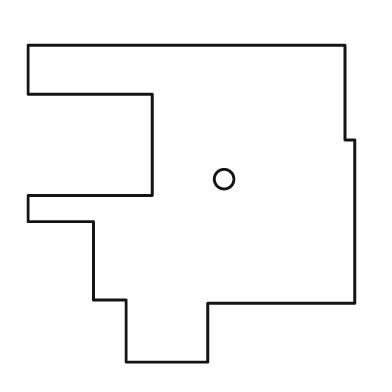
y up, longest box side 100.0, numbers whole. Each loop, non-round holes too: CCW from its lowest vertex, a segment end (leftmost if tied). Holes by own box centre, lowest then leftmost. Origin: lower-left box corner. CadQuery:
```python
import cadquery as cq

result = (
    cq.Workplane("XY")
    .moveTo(30.0, 0.0)
    .lineTo(55.0, 0.0)
    .lineTo(55.0, 18.0)
    .lineTo(100.0, 18.0)
    .lineTo(100.0, 68.0)
    .lineTo(97.0, 68.0)
    .lineTo(97.0, 97.0)
    .lineTo(0.0, 97.0)
    .lineTo(0.0, 82.0)
    .lineTo(38.0, 82.0)
    .lineTo(38.0, 51.0)
    .lineTo(0.0, 51.0)
    .lineTo(0.0, 43.0)
    .lineTo(20.0, 43.0)
    .lineTo(20.0, 19.0)
    .lineTo(30.0, 19.0)
    .close()
    .moveTo(60.0, 56.0)
    .circle(3.0)
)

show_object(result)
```